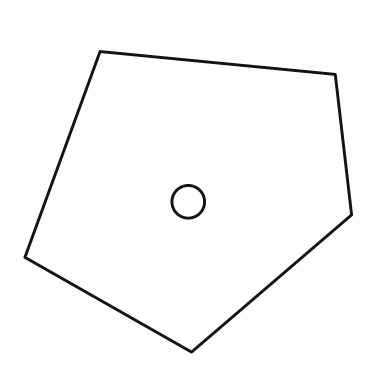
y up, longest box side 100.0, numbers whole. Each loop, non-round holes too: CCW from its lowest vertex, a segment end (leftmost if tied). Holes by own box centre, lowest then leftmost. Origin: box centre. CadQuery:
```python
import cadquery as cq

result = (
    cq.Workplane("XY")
    .moveTo(1.0, -46.0)
    .lineTo(50.0, -4.0)
    .lineTo(45.0, 39.0)
    .lineTo(-27.0, 46.0)
    .lineTo(-50.0, -17.0)
    .close()
    .moveTo(0.0, 0.0)
    .circle(5.0)
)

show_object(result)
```